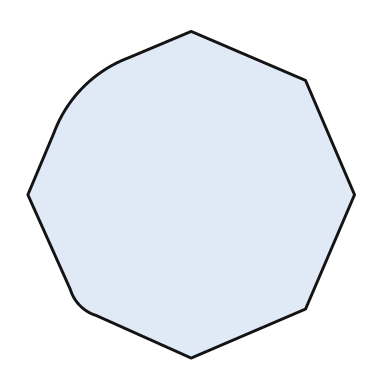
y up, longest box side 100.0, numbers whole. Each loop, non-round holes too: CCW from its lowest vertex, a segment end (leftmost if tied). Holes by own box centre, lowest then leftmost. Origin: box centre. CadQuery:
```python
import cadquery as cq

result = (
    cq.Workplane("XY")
    .moveTo(0.0, -50.0)
    .lineTo(35.0, -35.0)
    .lineTo(50.0, 0.0)
    .lineTo(35.0, 35.0)
    .lineTo(0.0, 50.0)
    .lineTo(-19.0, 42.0)
    .threePointArc((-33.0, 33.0), (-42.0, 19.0))
    .lineTo(-50.0, 0.0)
    .lineTo(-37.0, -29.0)
    .threePointArc((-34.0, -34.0), (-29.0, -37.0))
    .close()
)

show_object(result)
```